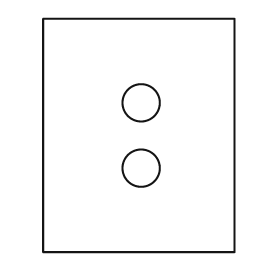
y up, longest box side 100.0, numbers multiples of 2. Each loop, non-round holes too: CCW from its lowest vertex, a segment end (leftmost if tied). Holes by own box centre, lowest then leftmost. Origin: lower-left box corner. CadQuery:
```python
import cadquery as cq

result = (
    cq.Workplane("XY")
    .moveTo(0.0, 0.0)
    .lineTo(82.0, 0.0)
    .lineTo(82.0, 100.0)
    .lineTo(0.0, 100.0)
    .close()
    .moveTo(42.0, 36.0)
    .circle(8.0)
    .moveTo(42.0, 64.0)
    .circle(8.0)
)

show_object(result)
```